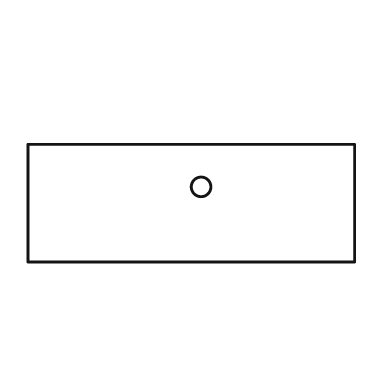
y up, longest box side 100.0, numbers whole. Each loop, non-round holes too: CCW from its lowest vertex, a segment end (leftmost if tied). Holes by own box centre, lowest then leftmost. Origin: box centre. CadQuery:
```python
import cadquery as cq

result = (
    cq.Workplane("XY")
    .moveTo(-50.0, -18.0)
    .lineTo(50.0, -18.0)
    .lineTo(50.0, 18.0)
    .lineTo(-50.0, 18.0)
    .close()
    .moveTo(3.0, 5.0)
    .circle(3.0)
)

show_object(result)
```